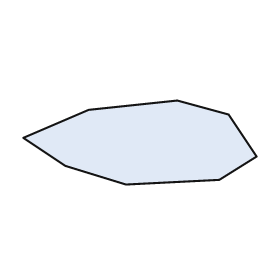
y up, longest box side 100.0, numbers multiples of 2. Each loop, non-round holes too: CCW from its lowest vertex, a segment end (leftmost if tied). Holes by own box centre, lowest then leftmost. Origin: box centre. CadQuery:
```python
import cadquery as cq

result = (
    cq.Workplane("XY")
    .moveTo(-6.0, -18.0)
    .lineTo(34.0, -16.0)
    .lineTo(50.0, -6.0)
    .lineTo(38.0, 12.0)
    .lineTo(16.0, 18.0)
    .lineTo(-22.0, 14.0)
    .lineTo(-50.0, 2.0)
    .lineTo(-32.0, -10.0)
    .close()
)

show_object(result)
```